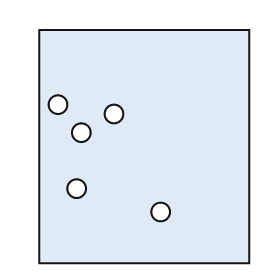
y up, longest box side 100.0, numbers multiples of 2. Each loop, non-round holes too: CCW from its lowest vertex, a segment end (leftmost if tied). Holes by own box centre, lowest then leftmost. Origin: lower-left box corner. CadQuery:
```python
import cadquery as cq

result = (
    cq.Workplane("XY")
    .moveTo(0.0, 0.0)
    .lineTo(90.0, 0.0)
    .lineTo(90.0, 100.0)
    .lineTo(0.0, 100.0)
    .close()
    .moveTo(52.0, 22.0)
    .circle(4.0)
    .moveTo(16.0, 32.0)
    .circle(4.0)
    .moveTo(18.0, 56.0)
    .circle(4.0)
    .moveTo(32.0, 64.0)
    .circle(4.0)
    .moveTo(8.0, 68.0)
    .circle(4.0)
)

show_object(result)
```